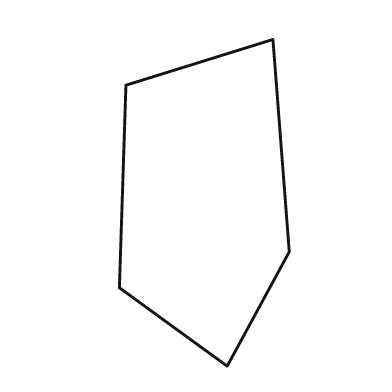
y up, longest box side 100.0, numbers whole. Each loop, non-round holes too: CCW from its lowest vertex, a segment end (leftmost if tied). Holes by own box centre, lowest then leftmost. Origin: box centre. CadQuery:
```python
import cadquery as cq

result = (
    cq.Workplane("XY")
    .moveTo(7.0, -50.0)
    .lineTo(26.0, -15.0)
    .lineTo(21.0, 50.0)
    .lineTo(-24.0, 36.0)
    .lineTo(-26.0, -26.0)
    .close()
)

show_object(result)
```